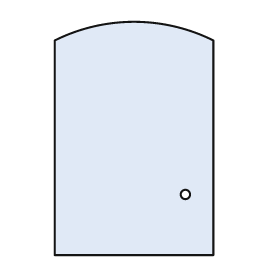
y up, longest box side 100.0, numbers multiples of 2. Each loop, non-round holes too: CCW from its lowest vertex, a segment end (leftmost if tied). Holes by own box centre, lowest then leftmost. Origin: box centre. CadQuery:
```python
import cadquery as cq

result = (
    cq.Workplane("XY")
    .moveTo(-34.0, -50.0)
    .lineTo(34.0, -50.0)
    .lineTo(34.0, 42.0)
    .threePointArc((0.0, 50.0), (-34.0, 42.0))
    .close()
    .moveTo(22.0, -24.0)
    .circle(2.0)
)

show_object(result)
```